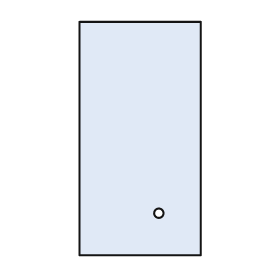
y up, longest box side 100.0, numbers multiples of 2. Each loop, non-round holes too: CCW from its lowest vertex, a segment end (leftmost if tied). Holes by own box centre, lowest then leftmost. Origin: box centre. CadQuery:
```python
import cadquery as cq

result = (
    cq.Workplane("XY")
    .moveTo(-26.0, -50.0)
    .lineTo(26.0, -50.0)
    .lineTo(26.0, 50.0)
    .lineTo(-26.0, 50.0)
    .close()
    .moveTo(8.0, -32.0)
    .circle(2.0)
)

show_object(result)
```